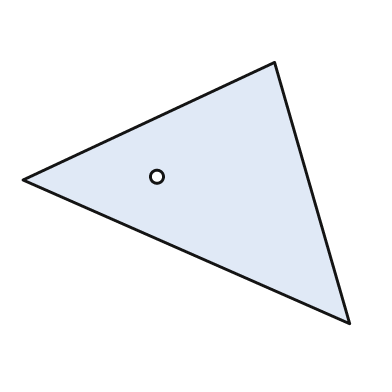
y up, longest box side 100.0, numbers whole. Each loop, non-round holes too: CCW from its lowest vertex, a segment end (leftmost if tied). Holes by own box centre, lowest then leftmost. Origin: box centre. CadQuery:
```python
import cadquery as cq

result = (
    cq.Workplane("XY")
    .moveTo(50.0, -40.0)
    .lineTo(27.0, 40.0)
    .lineTo(-50.0, 4.0)
    .close()
    .moveTo(-9.0, 5.0)
    .circle(2.0)
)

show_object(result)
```